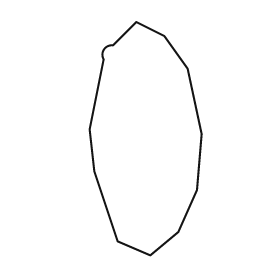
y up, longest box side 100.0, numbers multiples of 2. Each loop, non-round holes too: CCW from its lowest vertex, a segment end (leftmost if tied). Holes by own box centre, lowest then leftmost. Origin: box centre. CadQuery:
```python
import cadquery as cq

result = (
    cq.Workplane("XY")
    .moveTo(2.0, -50.0)
    .lineTo(14.0, -40.0)
    .lineTo(22.0, -22.0)
    .lineTo(24.0, 2.0)
    .lineTo(18.0, 30.0)
    .lineTo(8.0, 44.0)
    .lineTo(-4.0, 50.0)
    .lineTo(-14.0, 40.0)
    .threePointArc((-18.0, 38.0), (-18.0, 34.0))
    .lineTo(-24.0, 4.0)
    .lineTo(-22.0, -14.0)
    .lineTo(-12.0, -44.0)
    .close()
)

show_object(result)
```